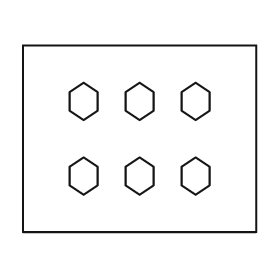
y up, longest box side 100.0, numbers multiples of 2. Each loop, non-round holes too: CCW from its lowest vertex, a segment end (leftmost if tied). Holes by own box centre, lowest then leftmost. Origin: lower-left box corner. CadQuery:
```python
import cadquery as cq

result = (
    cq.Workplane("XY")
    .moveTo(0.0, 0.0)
    .lineTo(100.0, 0.0)
    .lineTo(100.0, 80.0)
    .lineTo(0.0, 80.0)
    .close()
    .moveTo(26.0, 16.0)
    .lineTo(32.0, 20.0)
    .lineTo(32.0, 28.0)
    .lineTo(26.0, 32.0)
    .lineTo(20.0, 28.0)
    .lineTo(20.0, 20.0)
    .close()
    .moveTo(50.0, 16.0)
    .lineTo(56.0, 20.0)
    .lineTo(56.0, 28.0)
    .lineTo(50.0, 32.0)
    .lineTo(44.0, 28.0)
    .lineTo(44.0, 20.0)
    .close()
    .moveTo(74.0, 16.0)
    .lineTo(80.0, 20.0)
    .lineTo(80.0, 28.0)
    .lineTo(74.0, 32.0)
    .lineTo(68.0, 28.0)
    .lineTo(68.0, 20.0)
    .close()
    .moveTo(26.0, 48.0)
    .lineTo(32.0, 52.0)
    .lineTo(32.0, 60.0)
    .lineTo(26.0, 64.0)
    .lineTo(20.0, 60.0)
    .lineTo(20.0, 52.0)
    .close()
    .moveTo(50.0, 48.0)
    .lineTo(56.0, 52.0)
    .lineTo(56.0, 60.0)
    .lineTo(50.0, 64.0)
    .lineTo(44.0, 60.0)
    .lineTo(44.0, 52.0)
    .close()
    .moveTo(74.0, 48.0)
    .lineTo(80.0, 52.0)
    .lineTo(80.0, 60.0)
    .lineTo(74.0, 64.0)
    .lineTo(68.0, 60.0)
    .lineTo(68.0, 52.0)
    .close()
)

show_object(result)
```